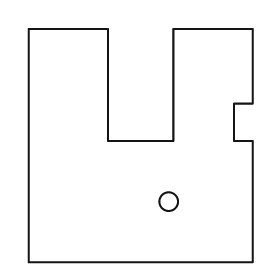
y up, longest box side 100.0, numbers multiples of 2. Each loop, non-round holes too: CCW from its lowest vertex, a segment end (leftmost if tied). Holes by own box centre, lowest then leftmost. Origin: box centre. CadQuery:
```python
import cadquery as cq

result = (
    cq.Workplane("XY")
    .moveTo(-48.0, -50.0)
    .lineTo(48.0, -50.0)
    .lineTo(48.0, 2.0)
    .lineTo(40.0, 2.0)
    .lineTo(40.0, 18.0)
    .lineTo(48.0, 18.0)
    .lineTo(48.0, 50.0)
    .lineTo(14.0, 50.0)
    .lineTo(14.0, 2.0)
    .lineTo(-14.0, 2.0)
    .lineTo(-14.0, 50.0)
    .lineTo(-48.0, 50.0)
    .close()
    .moveTo(12.0, -24.0)
    .circle(4.0)
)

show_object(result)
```